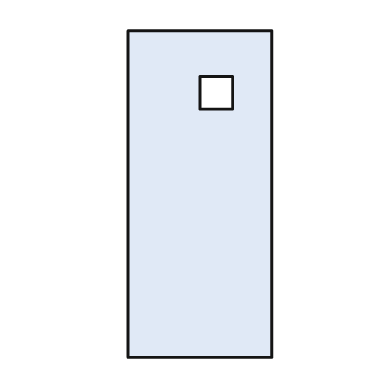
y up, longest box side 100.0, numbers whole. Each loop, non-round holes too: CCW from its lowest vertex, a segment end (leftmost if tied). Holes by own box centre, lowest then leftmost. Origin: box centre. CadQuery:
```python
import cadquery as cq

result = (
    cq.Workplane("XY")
    .moveTo(-22.0, -50.0)
    .lineTo(22.0, -50.0)
    .lineTo(22.0, 50.0)
    .lineTo(-22.0, 50.0)
    .close()
    .moveTo(0.0, 26.0)
    .lineTo(10.0, 26.0)
    .lineTo(10.0, 36.0)
    .lineTo(0.0, 36.0)
    .close()
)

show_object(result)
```